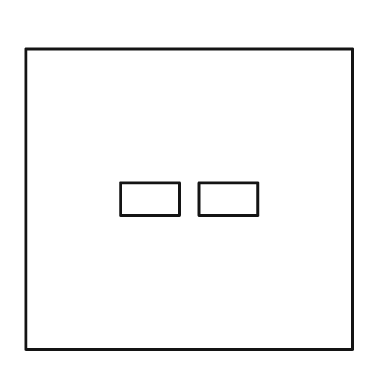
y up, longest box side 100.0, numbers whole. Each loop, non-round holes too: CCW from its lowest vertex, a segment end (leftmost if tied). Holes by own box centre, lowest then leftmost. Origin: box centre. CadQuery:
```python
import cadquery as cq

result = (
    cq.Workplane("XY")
    .moveTo(-50.0, -46.0)
    .lineTo(50.0, -46.0)
    .lineTo(50.0, 46.0)
    .lineTo(-50.0, 46.0)
    .close()
    .moveTo(-21.0, -5.0)
    .lineTo(-3.0, -5.0)
    .lineTo(-3.0, 5.0)
    .lineTo(-21.0, 5.0)
    .close()
    .moveTo(3.0, -5.0)
    .lineTo(21.0, -5.0)
    .lineTo(21.0, 5.0)
    .lineTo(3.0, 5.0)
    .close()
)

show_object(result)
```